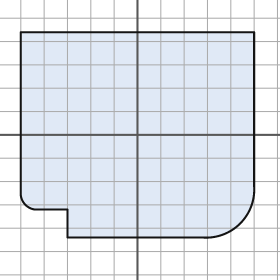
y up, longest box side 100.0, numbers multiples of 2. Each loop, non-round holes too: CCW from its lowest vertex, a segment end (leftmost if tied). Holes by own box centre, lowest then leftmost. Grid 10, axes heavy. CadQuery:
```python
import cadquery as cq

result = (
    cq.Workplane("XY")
    .moveTo(-30.0, -44.0)
    .lineTo(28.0, -44.0)
    .threePointArc((44.0, -38.0), (50.0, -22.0))
    .lineTo(50.0, 44.0)
    .lineTo(-50.0, 44.0)
    .lineTo(-50.0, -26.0)
    .threePointArc((-48.0, -30.0), (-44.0, -32.0))
    .lineTo(-30.0, -32.0)
    .close()
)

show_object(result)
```